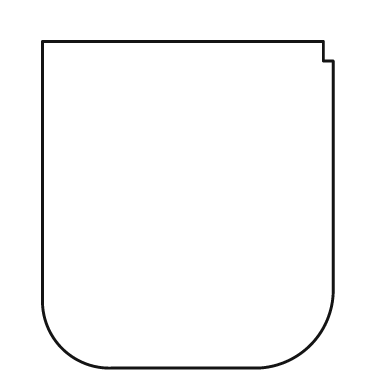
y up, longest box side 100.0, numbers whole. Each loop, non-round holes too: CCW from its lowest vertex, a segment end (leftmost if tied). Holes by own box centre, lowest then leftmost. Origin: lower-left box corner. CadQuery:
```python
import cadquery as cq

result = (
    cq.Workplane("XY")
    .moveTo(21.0, 0.0)
    .lineTo(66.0, 0.0)
    .threePointArc((82.0, 7.0), (89.0, 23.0))
    .lineTo(89.0, 94.0)
    .lineTo(86.0, 94.0)
    .lineTo(86.0, 100.0)
    .lineTo(0.0, 100.0)
    .lineTo(0.0, 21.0)
    .threePointArc((6.0, 6.0), (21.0, 0.0))
    .close()
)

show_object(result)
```